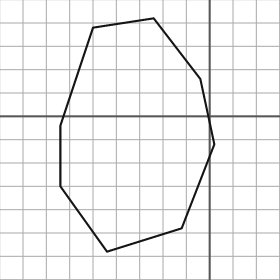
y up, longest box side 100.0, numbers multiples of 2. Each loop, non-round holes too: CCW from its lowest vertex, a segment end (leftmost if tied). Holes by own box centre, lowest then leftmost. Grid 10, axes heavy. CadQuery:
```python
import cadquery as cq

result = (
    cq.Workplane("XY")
    .moveTo(-44.0, -58.0)
    .lineTo(-12.0, -48.0)
    .lineTo(2.0, -12.0)
    .lineTo(-4.0, 16.0)
    .lineTo(-24.0, 42.0)
    .lineTo(-50.0, 38.0)
    .lineTo(-64.0, -4.0)
    .lineTo(-64.0, -30.0)
    .close()
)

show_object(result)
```